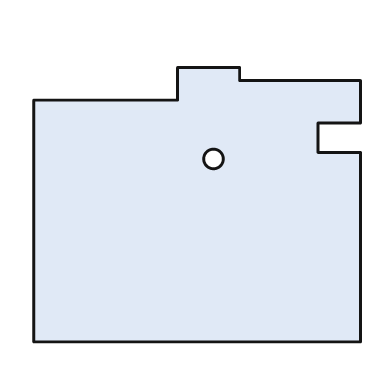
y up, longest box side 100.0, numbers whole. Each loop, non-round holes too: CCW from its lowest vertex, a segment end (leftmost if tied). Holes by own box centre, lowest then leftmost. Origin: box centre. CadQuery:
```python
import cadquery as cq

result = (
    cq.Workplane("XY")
    .moveTo(-50.0, -42.0)
    .lineTo(50.0, -42.0)
    .lineTo(50.0, 16.0)
    .lineTo(37.0, 16.0)
    .lineTo(37.0, 25.0)
    .lineTo(50.0, 25.0)
    .lineTo(50.0, 38.0)
    .lineTo(13.0, 38.0)
    .lineTo(13.0, 42.0)
    .lineTo(-6.0, 42.0)
    .lineTo(-6.0, 32.0)
    .lineTo(-50.0, 32.0)
    .close()
    .moveTo(5.0, 14.0)
    .circle(3.0)
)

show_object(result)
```